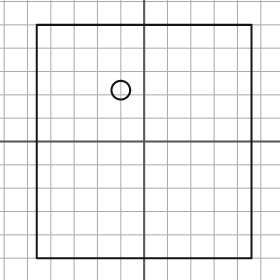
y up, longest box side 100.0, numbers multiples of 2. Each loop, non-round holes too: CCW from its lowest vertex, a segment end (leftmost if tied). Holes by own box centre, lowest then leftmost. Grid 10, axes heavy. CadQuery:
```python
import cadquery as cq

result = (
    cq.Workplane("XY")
    .moveTo(-46.0, -50.0)
    .lineTo(46.0, -50.0)
    .lineTo(46.0, 50.0)
    .lineTo(-46.0, 50.0)
    .close()
    .moveTo(-10.0, 22.0)
    .circle(4.0)
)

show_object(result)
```